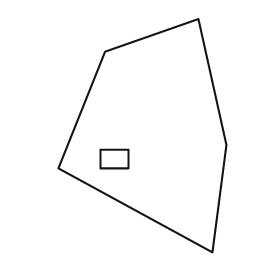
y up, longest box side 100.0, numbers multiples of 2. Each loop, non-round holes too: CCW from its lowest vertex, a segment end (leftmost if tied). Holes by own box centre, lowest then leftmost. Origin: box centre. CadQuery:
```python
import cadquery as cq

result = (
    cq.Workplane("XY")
    .moveTo(30.0, -50.0)
    .lineTo(36.0, -4.0)
    .lineTo(24.0, 50.0)
    .lineTo(-16.0, 36.0)
    .lineTo(-36.0, -14.0)
    .close()
    .moveTo(-18.0, -14.0)
    .lineTo(-6.0, -14.0)
    .lineTo(-6.0, -6.0)
    .lineTo(-18.0, -6.0)
    .close()
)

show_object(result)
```